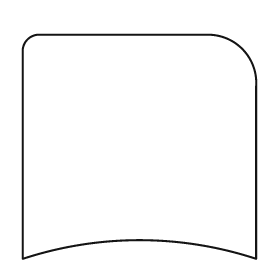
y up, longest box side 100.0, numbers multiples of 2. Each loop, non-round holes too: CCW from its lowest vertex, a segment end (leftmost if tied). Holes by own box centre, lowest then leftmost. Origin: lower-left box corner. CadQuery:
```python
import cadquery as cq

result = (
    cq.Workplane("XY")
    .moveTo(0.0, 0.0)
    .threePointArc((50.0, 8.0), (100.0, 0.0))
    .lineTo(100.0, 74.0)
    .threePointArc((94.0, 90.0), (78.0, 96.0))
    .lineTo(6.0, 96.0)
    .threePointArc((2.0, 94.0), (0.0, 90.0))
    .close()
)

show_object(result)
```